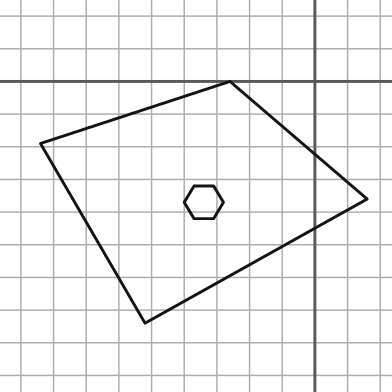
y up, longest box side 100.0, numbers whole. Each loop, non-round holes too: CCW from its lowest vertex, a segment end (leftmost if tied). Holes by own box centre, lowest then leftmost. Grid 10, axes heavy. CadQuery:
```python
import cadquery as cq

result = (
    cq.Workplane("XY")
    .moveTo(-52.0, -74.0)
    .lineTo(16.0, -36.0)
    .lineTo(-26.0, 0.0)
    .lineTo(-84.0, -19.0)
    .close()
    .moveTo(-37.0, -42.0)
    .lineTo(-31.0, -42.0)
    .lineTo(-28.0, -37.0)
    .lineTo(-31.0, -32.0)
    .lineTo(-37.0, -32.0)
    .lineTo(-40.0, -37.0)
    .close()
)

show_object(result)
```